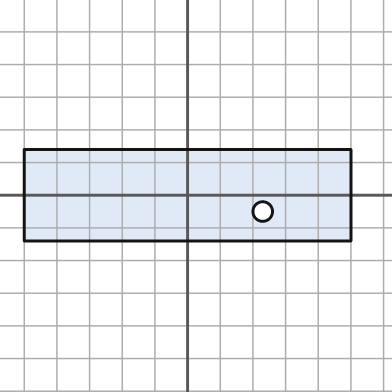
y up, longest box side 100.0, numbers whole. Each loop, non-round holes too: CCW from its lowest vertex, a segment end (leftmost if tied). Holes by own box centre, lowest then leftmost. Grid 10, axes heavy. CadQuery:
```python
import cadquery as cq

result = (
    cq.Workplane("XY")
    .moveTo(-50.0, -14.0)
    .lineTo(50.0, -14.0)
    .lineTo(50.0, 14.0)
    .lineTo(-50.0, 14.0)
    .close()
    .moveTo(23.0, -5.0)
    .circle(3.0)
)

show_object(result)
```